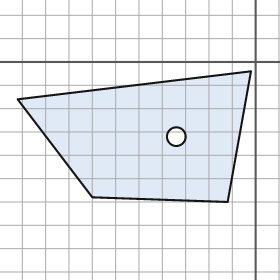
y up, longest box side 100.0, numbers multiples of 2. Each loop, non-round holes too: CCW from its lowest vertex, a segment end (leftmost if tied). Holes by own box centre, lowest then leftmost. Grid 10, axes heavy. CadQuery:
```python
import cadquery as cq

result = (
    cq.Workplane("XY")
    .moveTo(-12.0, -60.0)
    .lineTo(-2.0, -4.0)
    .lineTo(-102.0, -16.0)
    .lineTo(-70.0, -58.0)
    .close()
    .moveTo(-34.0, -32.0)
    .circle(4.0)
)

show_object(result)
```